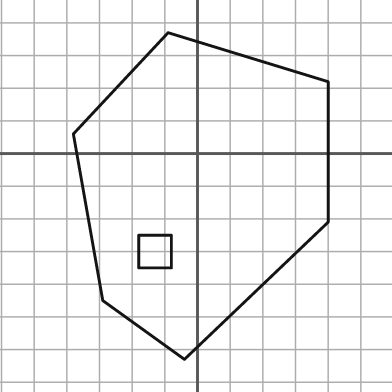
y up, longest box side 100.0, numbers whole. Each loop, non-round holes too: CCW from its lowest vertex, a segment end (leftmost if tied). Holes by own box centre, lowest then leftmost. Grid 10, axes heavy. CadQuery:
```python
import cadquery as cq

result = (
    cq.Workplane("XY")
    .moveTo(-4.0, -63.0)
    .lineTo(40.0, -21.0)
    .lineTo(40.0, 22.0)
    .lineTo(-9.0, 37.0)
    .lineTo(-38.0, 6.0)
    .lineTo(-29.0, -45.0)
    .close()
    .moveTo(-18.0, -35.0)
    .lineTo(-8.0, -35.0)
    .lineTo(-8.0, -25.0)
    .lineTo(-18.0, -25.0)
    .close()
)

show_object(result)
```